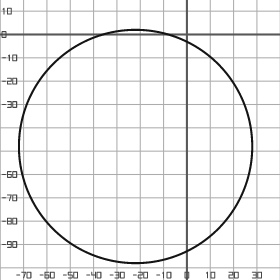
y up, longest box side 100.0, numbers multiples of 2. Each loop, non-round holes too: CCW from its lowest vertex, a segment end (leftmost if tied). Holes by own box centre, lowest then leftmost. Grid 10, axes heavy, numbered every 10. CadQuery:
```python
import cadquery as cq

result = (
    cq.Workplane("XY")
    .moveTo(-22.0, -48.0)
    .circle(50.0)
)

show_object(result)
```